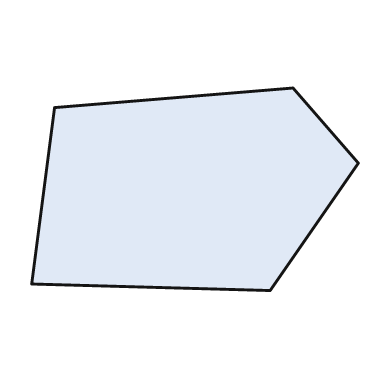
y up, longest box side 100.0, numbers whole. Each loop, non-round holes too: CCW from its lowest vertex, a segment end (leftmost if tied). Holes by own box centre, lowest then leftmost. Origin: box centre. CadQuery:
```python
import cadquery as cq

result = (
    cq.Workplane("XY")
    .moveTo(23.0, -31.0)
    .lineTo(50.0, 8.0)
    .lineTo(30.0, 31.0)
    .lineTo(-43.0, 25.0)
    .lineTo(-50.0, -29.0)
    .close()
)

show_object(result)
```